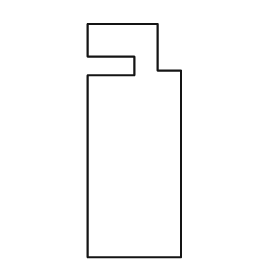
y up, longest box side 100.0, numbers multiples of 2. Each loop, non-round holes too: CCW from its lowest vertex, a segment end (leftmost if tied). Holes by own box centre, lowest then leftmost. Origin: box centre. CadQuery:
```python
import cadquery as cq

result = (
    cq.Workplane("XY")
    .moveTo(-20.0, -50.0)
    .lineTo(20.0, -50.0)
    .lineTo(20.0, 30.0)
    .lineTo(10.0, 30.0)
    .lineTo(10.0, 50.0)
    .lineTo(-20.0, 50.0)
    .lineTo(-20.0, 36.0)
    .lineTo(0.0, 36.0)
    .lineTo(0.0, 28.0)
    .lineTo(-20.0, 28.0)
    .close()
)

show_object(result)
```